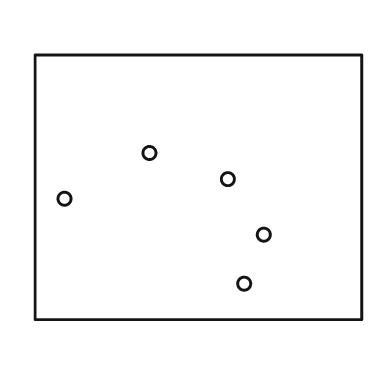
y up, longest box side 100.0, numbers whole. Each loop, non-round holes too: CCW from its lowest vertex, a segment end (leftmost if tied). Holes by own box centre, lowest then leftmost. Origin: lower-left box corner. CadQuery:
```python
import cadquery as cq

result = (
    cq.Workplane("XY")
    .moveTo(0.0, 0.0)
    .lineTo(100.0, 0.0)
    .lineTo(100.0, 81.0)
    .lineTo(0.0, 81.0)
    .close()
    .moveTo(64.0, 11.0)
    .circle(2.0)
    .moveTo(70.0, 26.0)
    .circle(2.0)
    .moveTo(9.0, 37.0)
    .circle(2.0)
    .moveTo(59.0, 43.0)
    .circle(2.0)
    .moveTo(35.0, 51.0)
    .circle(2.0)
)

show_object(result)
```